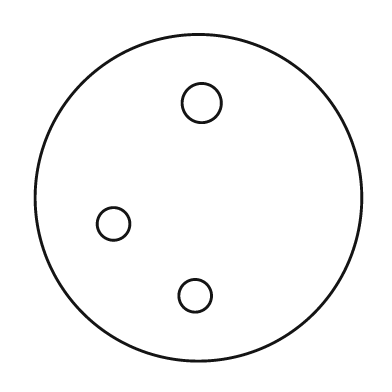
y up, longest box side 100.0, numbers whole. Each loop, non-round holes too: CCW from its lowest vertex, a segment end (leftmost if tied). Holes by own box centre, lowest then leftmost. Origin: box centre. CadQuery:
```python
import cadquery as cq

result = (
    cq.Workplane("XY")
    .moveTo(0.0, 0.0)
    .circle(50.0)
    .moveTo(-1.0, -30.0)
    .circle(5.0)
    .moveTo(-26.0, -8.0)
    .circle(5.0)
    .moveTo(1.0, 29.0)
    .circle(6.0)
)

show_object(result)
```